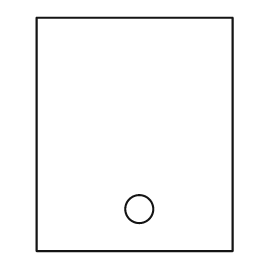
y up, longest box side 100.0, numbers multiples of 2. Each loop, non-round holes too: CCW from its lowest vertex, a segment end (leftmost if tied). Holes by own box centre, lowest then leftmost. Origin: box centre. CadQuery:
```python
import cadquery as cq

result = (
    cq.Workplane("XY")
    .moveTo(-42.0, -50.0)
    .lineTo(42.0, -50.0)
    .lineTo(42.0, 50.0)
    .lineTo(-42.0, 50.0)
    .close()
    .moveTo(2.0, -32.0)
    .circle(6.0)
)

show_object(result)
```